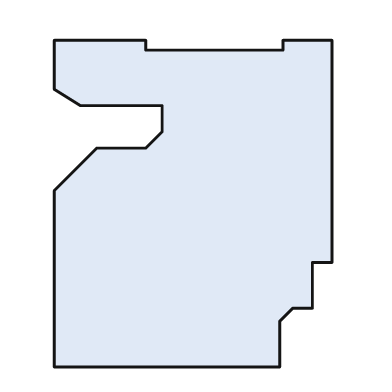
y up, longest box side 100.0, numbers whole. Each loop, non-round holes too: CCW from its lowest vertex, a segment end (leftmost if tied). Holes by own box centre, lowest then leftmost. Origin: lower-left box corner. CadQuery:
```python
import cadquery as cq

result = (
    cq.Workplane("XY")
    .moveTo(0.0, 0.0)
    .lineTo(69.0, 0.0)
    .lineTo(69.0, 14.0)
    .lineTo(73.0, 18.0)
    .lineTo(79.0, 18.0)
    .lineTo(79.0, 32.0)
    .lineTo(85.0, 32.0)
    .lineTo(85.0, 100.0)
    .lineTo(70.0, 100.0)
    .lineTo(70.0, 97.0)
    .lineTo(28.0, 97.0)
    .lineTo(28.0, 100.0)
    .lineTo(0.0, 100.0)
    .lineTo(0.0, 85.0)
    .lineTo(8.0, 80.0)
    .lineTo(33.0, 80.0)
    .lineTo(33.0, 72.0)
    .lineTo(28.0, 67.0)
    .lineTo(13.0, 67.0)
    .lineTo(0.0, 54.0)
    .close()
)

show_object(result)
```